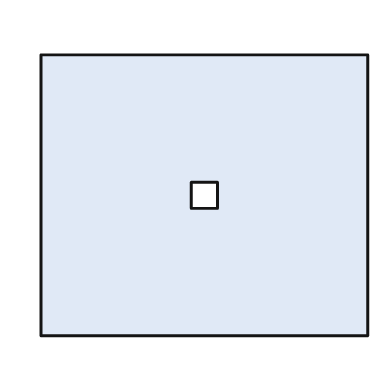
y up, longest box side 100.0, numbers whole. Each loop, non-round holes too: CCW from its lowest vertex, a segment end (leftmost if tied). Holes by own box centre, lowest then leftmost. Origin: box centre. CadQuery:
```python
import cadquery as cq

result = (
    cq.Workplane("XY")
    .moveTo(-50.0, -43.0)
    .lineTo(50.0, -43.0)
    .lineTo(50.0, 43.0)
    .lineTo(-50.0, 43.0)
    .close()
    .moveTo(-4.0, -4.0)
    .lineTo(4.0, -4.0)
    .lineTo(4.0, 4.0)
    .lineTo(-4.0, 4.0)
    .close()
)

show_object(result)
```